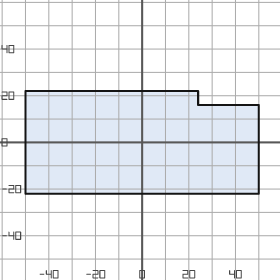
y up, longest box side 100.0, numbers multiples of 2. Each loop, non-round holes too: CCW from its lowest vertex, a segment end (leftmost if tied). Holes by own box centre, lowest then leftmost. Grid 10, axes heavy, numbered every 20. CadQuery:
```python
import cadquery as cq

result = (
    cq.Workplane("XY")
    .moveTo(-50.0, -22.0)
    .lineTo(50.0, -22.0)
    .lineTo(50.0, 16.0)
    .lineTo(24.0, 16.0)
    .lineTo(24.0, 22.0)
    .lineTo(-50.0, 22.0)
    .close()
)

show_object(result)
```